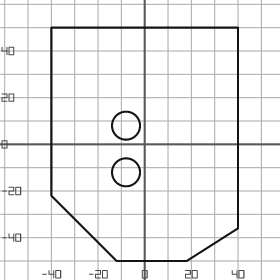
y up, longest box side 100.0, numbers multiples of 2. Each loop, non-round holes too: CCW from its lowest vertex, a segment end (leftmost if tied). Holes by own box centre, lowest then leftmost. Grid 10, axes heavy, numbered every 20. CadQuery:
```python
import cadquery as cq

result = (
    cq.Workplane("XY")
    .moveTo(-12.0, -50.0)
    .lineTo(18.0, -50.0)
    .lineTo(40.0, -36.0)
    .lineTo(40.0, 50.0)
    .lineTo(-40.0, 50.0)
    .lineTo(-40.0, -22.0)
    .close()
    .moveTo(-8.0, -12.0)
    .circle(6.0)
    .moveTo(-8.0, 8.0)
    .circle(6.0)
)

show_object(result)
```